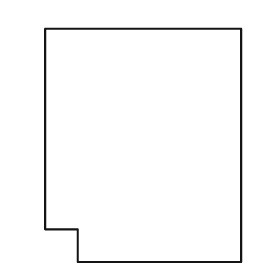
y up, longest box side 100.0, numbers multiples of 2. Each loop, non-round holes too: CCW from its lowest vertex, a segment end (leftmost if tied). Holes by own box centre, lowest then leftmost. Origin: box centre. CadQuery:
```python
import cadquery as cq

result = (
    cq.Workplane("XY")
    .moveTo(-28.0, -50.0)
    .lineTo(42.0, -50.0)
    .lineTo(42.0, 50.0)
    .lineTo(-42.0, 50.0)
    .lineTo(-42.0, -36.0)
    .lineTo(-28.0, -36.0)
    .close()
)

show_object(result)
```